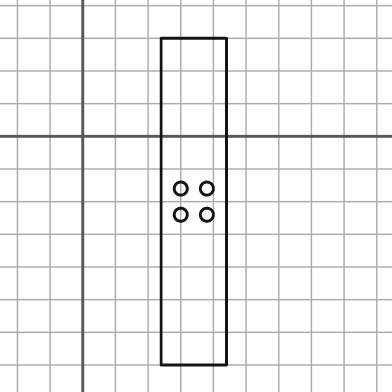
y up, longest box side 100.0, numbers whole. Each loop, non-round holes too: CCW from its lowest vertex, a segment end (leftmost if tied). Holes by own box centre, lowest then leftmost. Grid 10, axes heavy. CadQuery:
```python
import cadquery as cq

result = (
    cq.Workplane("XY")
    .moveTo(24.0, -70.0)
    .lineTo(44.0, -70.0)
    .lineTo(44.0, 30.0)
    .lineTo(24.0, 30.0)
    .close()
    .moveTo(30.0, -24.0)
    .circle(2.0)
    .moveTo(38.0, -24.0)
    .circle(2.0)
    .moveTo(30.0, -16.0)
    .circle(2.0)
    .moveTo(38.0, -16.0)
    .circle(2.0)
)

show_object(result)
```